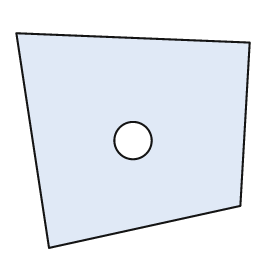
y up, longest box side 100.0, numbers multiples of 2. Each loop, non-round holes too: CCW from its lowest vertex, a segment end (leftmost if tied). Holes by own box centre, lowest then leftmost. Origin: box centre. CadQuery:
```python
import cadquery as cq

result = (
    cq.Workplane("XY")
    .moveTo(-36.0, -46.0)
    .lineTo(46.0, -28.0)
    .lineTo(50.0, 42.0)
    .lineTo(-50.0, 46.0)
    .close()
    .moveTo(0.0, 0.0)
    .circle(8.0)
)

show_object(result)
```